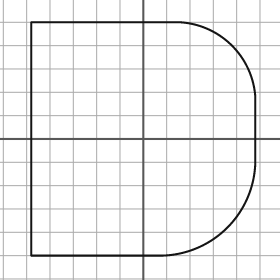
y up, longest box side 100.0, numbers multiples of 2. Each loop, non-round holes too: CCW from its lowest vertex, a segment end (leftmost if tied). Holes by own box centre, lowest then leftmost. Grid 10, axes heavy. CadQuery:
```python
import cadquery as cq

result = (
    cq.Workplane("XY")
    .moveTo(-48.0, -50.0)
    .lineTo(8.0, -50.0)
    .threePointArc((36.0, -38.0), (48.0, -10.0))
    .lineTo(48.0, 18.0)
    .threePointArc((38.0, 40.0), (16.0, 50.0))
    .lineTo(-48.0, 50.0)
    .close()
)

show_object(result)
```